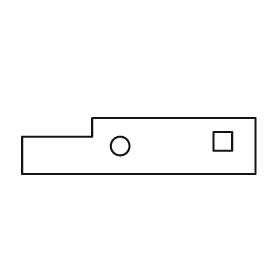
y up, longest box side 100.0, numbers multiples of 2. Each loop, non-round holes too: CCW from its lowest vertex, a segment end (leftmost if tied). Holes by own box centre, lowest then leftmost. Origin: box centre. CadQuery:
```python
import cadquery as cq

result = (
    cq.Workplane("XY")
    .moveTo(-50.0, -12.0)
    .lineTo(50.0, -12.0)
    .lineTo(50.0, 12.0)
    .lineTo(-20.0, 12.0)
    .lineTo(-20.0, 4.0)
    .lineTo(-50.0, 4.0)
    .close()
    .moveTo(-8.0, 0.0)
    .circle(4.0)
    .moveTo(32.0, -2.0)
    .lineTo(40.0, -2.0)
    .lineTo(40.0, 6.0)
    .lineTo(32.0, 6.0)
    .close()
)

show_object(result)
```